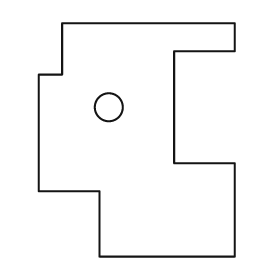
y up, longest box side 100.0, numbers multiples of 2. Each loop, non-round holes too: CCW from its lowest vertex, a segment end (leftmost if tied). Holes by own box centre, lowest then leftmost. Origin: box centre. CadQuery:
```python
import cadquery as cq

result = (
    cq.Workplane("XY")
    .moveTo(-16.0, -50.0)
    .lineTo(42.0, -50.0)
    .lineTo(42.0, -10.0)
    .lineTo(16.0, -10.0)
    .lineTo(16.0, 38.0)
    .lineTo(42.0, 38.0)
    .lineTo(42.0, 50.0)
    .lineTo(-32.0, 50.0)
    .lineTo(-32.0, 28.0)
    .lineTo(-42.0, 28.0)
    .lineTo(-42.0, -22.0)
    .lineTo(-16.0, -22.0)
    .close()
    .moveTo(-12.0, 14.0)
    .circle(6.0)
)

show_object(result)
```